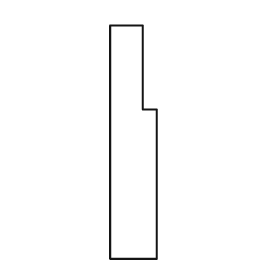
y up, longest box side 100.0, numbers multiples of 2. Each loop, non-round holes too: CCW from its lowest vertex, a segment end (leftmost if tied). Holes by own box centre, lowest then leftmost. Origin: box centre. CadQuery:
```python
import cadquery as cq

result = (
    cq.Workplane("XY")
    .moveTo(-10.0, -50.0)
    .lineTo(10.0, -50.0)
    .lineTo(10.0, 14.0)
    .lineTo(4.0, 14.0)
    .lineTo(4.0, 50.0)
    .lineTo(-10.0, 50.0)
    .close()
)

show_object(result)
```